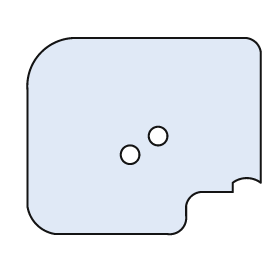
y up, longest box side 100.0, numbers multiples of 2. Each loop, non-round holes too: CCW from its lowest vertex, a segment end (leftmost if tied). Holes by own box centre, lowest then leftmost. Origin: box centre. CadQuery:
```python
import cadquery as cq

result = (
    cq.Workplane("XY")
    .moveTo(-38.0, -42.0)
    .lineTo(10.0, -42.0)
    .threePointArc((16.0, -40.0), (18.0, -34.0))
    .lineTo(18.0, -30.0)
    .threePointArc((20.0, -26.0), (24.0, -24.0))
    .lineTo(38.0, -24.0)
    .lineTo(38.0, -20.0)
    .threePointArc((44.0, -18.0), (50.0, -20.0))
    .lineTo(50.0, 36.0)
    .threePointArc((48.0, 40.0), (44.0, 42.0))
    .lineTo(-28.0, 42.0)
    .threePointArc((-44.0, 36.0), (-50.0, 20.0))
    .lineTo(-50.0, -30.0)
    .threePointArc((-46.0, -38.0), (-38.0, -42.0))
    .close()
    .moveTo(-6.0, -8.0)
    .circle(4.0)
    .moveTo(6.0, 0.0)
    .circle(4.0)
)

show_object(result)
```